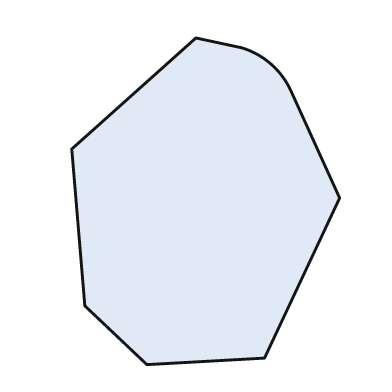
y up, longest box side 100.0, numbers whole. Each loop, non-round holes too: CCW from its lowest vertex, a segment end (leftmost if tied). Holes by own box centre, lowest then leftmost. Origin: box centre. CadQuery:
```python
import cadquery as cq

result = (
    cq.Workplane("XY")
    .moveTo(-18.0, -50.0)
    .lineTo(18.0, -48.0)
    .lineTo(41.0, 1.0)
    .lineTo(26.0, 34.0)
    .threePointArc((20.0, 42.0), (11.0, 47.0))
    .lineTo(-3.0, 50.0)
    .lineTo(-41.0, 16.0)
    .lineTo(-37.0, -32.0)
    .close()
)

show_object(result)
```